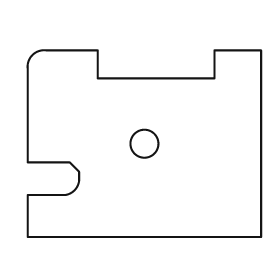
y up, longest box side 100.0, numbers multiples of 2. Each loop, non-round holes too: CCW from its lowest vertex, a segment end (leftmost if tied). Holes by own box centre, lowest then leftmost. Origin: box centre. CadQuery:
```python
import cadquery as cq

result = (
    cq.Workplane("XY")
    .moveTo(-50.0, -40.0)
    .lineTo(50.0, -40.0)
    .lineTo(50.0, 40.0)
    .lineTo(30.0, 40.0)
    .lineTo(30.0, 28.0)
    .lineTo(-20.0, 28.0)
    .lineTo(-20.0, 40.0)
    .lineTo(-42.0, 40.0)
    .threePointArc((-48.0, 38.0), (-50.0, 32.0))
    .lineTo(-50.0, -8.0)
    .lineTo(-32.0, -8.0)
    .lineTo(-28.0, -12.0)
    .lineTo(-28.0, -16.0)
    .threePointArc((-30.0, -20.0), (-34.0, -22.0))
    .lineTo(-50.0, -22.0)
    .close()
    .moveTo(0.0, 0.0)
    .circle(6.0)
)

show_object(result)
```